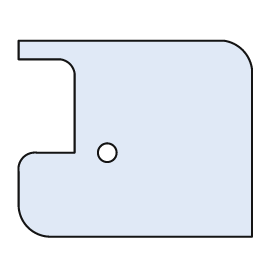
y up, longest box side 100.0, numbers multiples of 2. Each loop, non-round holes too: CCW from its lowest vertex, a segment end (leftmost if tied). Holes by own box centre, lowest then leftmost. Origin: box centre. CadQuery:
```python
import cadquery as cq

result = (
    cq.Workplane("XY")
    .moveTo(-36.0, -42.0)
    .lineTo(50.0, -42.0)
    .lineTo(50.0, 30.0)
    .threePointArc((46.0, 38.0), (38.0, 42.0))
    .lineTo(-50.0, 42.0)
    .lineTo(-50.0, 34.0)
    .lineTo(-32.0, 34.0)
    .threePointArc((-28.0, 32.0), (-26.0, 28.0))
    .lineTo(-26.0, -6.0)
    .lineTo(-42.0, -6.0)
    .threePointArc((-48.0, -8.0), (-50.0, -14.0))
    .lineTo(-50.0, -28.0)
    .threePointArc((-46.0, -38.0), (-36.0, -42.0))
    .close()
    .moveTo(-12.0, -6.0)
    .circle(4.0)
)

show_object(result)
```